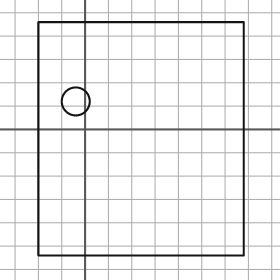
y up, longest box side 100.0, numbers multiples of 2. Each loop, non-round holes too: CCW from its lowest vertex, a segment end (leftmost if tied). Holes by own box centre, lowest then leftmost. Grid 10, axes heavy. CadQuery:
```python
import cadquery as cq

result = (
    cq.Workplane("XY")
    .moveTo(-20.0, -54.0)
    .lineTo(68.0, -54.0)
    .lineTo(68.0, 46.0)
    .lineTo(-20.0, 46.0)
    .close()
    .moveTo(-4.0, 12.0)
    .circle(6.0)
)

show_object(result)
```